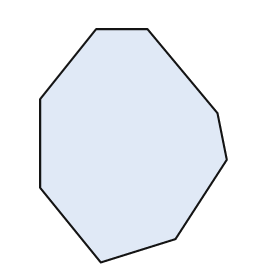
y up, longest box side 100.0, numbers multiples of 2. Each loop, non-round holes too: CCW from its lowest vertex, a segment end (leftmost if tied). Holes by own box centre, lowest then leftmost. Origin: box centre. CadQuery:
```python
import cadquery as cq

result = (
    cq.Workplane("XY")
    .moveTo(-14.0, -50.0)
    .lineTo(18.0, -40.0)
    .lineTo(40.0, -6.0)
    .lineTo(36.0, 14.0)
    .lineTo(6.0, 50.0)
    .lineTo(-16.0, 50.0)
    .lineTo(-40.0, 20.0)
    .lineTo(-40.0, -18.0)
    .close()
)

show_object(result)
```